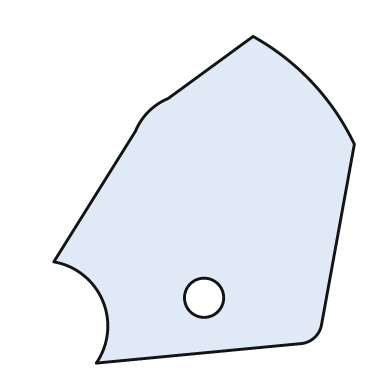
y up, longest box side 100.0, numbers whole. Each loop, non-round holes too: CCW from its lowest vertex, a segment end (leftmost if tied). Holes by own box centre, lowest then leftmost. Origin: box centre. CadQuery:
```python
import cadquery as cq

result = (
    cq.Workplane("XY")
    .moveTo(-33.0, -50.0)
    .lineTo(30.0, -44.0)
    .threePointArc((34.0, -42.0), (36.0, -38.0))
    .lineTo(46.0, 17.0)
    .threePointArc((33.0, 36.0), (15.0, 50.0))
    .lineTo(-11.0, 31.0)
    .threePointArc((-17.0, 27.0), (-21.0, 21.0))
    .lineTo(-46.0, -19.0)
    .threePointArc((-31.0, -31.0), (-33.0, -50.0))
    .close()
    .moveTo(0.0, -30.0)
    .circle(6.0)
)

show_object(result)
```